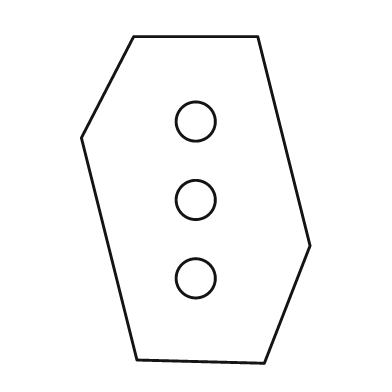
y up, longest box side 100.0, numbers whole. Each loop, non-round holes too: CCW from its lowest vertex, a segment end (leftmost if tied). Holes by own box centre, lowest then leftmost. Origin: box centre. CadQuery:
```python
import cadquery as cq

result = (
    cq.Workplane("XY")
    .moveTo(21.0, -50.0)
    .lineTo(35.0, -14.0)
    .lineTo(19.0, 50.0)
    .lineTo(-19.0, 50.0)
    .lineTo(-35.0, 19.0)
    .lineTo(-18.0, -49.0)
    .close()
    .moveTo(0.0, -24.0)
    .circle(6.0)
    .moveTo(0.0, 0.0)
    .circle(6.0)
    .moveTo(0.0, 24.0)
    .circle(6.0)
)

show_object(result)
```